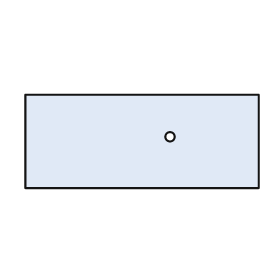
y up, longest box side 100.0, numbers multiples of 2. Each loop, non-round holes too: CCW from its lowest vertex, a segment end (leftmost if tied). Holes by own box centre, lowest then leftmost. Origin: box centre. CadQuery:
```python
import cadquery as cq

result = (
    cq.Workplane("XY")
    .moveTo(-50.0, -20.0)
    .lineTo(50.0, -20.0)
    .lineTo(50.0, 20.0)
    .lineTo(-50.0, 20.0)
    .close()
    .moveTo(12.0, 2.0)
    .circle(2.0)
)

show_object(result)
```